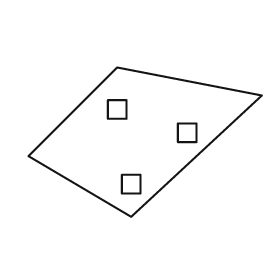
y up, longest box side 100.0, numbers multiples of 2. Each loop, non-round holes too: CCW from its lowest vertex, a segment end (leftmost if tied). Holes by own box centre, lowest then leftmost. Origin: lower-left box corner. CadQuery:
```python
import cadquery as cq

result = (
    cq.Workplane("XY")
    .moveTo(44.0, 0.0)
    .lineTo(100.0, 52.0)
    .lineTo(38.0, 64.0)
    .lineTo(0.0, 26.0)
    .close()
    .moveTo(40.0, 10.0)
    .lineTo(48.0, 10.0)
    .lineTo(48.0, 18.0)
    .lineTo(40.0, 18.0)
    .close()
    .moveTo(64.0, 32.0)
    .lineTo(72.0, 32.0)
    .lineTo(72.0, 40.0)
    .lineTo(64.0, 40.0)
    .close()
    .moveTo(34.0, 42.0)
    .lineTo(42.0, 42.0)
    .lineTo(42.0, 50.0)
    .lineTo(34.0, 50.0)
    .close()
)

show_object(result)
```